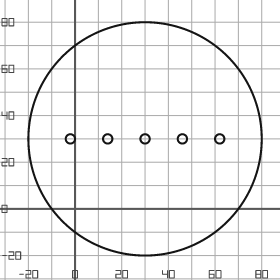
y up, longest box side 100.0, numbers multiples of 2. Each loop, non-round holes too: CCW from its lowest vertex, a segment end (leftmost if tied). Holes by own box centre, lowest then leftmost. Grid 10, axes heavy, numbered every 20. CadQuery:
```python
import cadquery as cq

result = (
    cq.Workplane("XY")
    .moveTo(30.0, 30.0)
    .circle(50.0)
    .moveTo(-2.0, 30.0)
    .circle(2.0)
    .moveTo(14.0, 30.0)
    .circle(2.0)
    .moveTo(30.0, 30.0)
    .circle(2.0)
    .moveTo(46.0, 30.0)
    .circle(2.0)
    .moveTo(62.0, 30.0)
    .circle(2.0)
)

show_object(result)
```